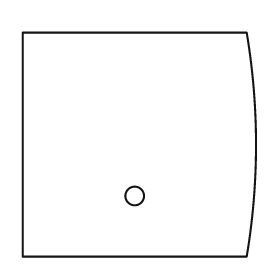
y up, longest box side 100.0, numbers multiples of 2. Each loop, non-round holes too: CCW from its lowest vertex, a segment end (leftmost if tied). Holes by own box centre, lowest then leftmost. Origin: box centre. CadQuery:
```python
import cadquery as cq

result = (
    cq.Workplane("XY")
    .moveTo(-50.0, -48.0)
    .lineTo(46.0, -48.0)
    .threePointArc((50.0, 0.0), (46.0, 48.0))
    .lineTo(-50.0, 48.0)
    .close()
    .moveTo(-2.0, -22.0)
    .circle(4.0)
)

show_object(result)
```